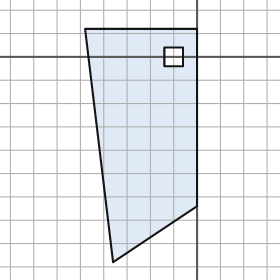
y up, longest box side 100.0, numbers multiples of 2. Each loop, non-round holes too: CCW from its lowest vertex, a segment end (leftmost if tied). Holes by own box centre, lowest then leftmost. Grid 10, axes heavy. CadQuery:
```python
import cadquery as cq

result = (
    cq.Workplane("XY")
    .moveTo(-36.0, -88.0)
    .lineTo(0.0, -64.0)
    .lineTo(0.0, 12.0)
    .lineTo(-48.0, 12.0)
    .close()
    .moveTo(-14.0, -4.0)
    .lineTo(-6.0, -4.0)
    .lineTo(-6.0, 4.0)
    .lineTo(-14.0, 4.0)
    .close()
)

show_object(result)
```